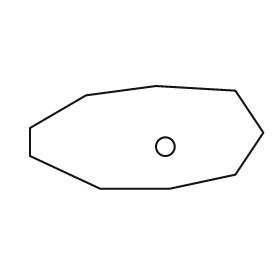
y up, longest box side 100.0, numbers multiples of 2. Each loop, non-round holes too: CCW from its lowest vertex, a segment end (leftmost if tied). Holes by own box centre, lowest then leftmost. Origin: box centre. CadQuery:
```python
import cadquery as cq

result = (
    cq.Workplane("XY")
    .moveTo(-20.0, -22.0)
    .lineTo(10.0, -22.0)
    .lineTo(38.0, -16.0)
    .lineTo(50.0, 2.0)
    .lineTo(38.0, 20.0)
    .lineTo(4.0, 22.0)
    .lineTo(-26.0, 18.0)
    .lineTo(-50.0, 4.0)
    .lineTo(-50.0, -8.0)
    .close()
    .moveTo(8.0, -4.0)
    .circle(4.0)
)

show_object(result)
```